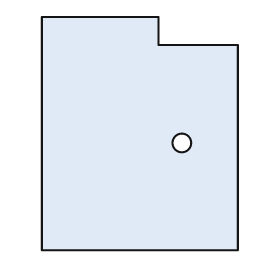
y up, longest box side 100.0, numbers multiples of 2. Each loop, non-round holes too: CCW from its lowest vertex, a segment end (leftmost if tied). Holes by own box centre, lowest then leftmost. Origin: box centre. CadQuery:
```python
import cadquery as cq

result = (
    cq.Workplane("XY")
    .moveTo(-42.0, -50.0)
    .lineTo(42.0, -50.0)
    .lineTo(42.0, 38.0)
    .lineTo(8.0, 38.0)
    .lineTo(8.0, 50.0)
    .lineTo(-42.0, 50.0)
    .close()
    .moveTo(18.0, -4.0)
    .circle(4.0)
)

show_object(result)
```